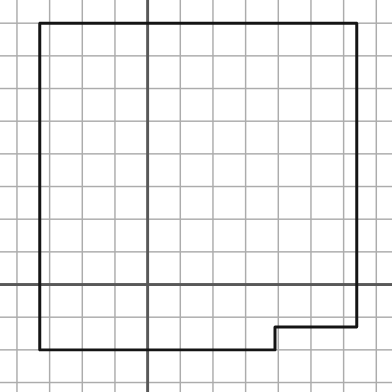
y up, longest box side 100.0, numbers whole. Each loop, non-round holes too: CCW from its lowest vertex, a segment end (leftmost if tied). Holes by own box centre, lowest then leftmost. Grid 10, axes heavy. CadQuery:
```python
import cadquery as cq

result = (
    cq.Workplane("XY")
    .moveTo(-33.0, -20.0)
    .lineTo(39.0, -20.0)
    .lineTo(39.0, -13.0)
    .lineTo(64.0, -13.0)
    .lineTo(64.0, 80.0)
    .lineTo(-33.0, 80.0)
    .close()
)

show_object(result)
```